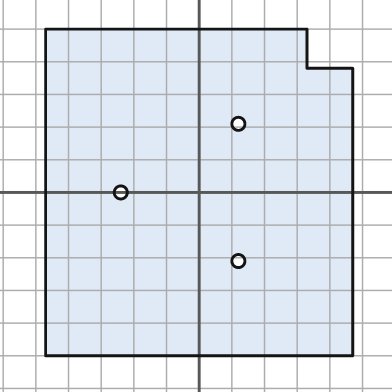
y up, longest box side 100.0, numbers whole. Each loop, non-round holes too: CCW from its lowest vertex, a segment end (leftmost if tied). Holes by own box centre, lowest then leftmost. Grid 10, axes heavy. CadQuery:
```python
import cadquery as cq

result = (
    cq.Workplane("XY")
    .moveTo(-47.0, -50.0)
    .lineTo(47.0, -50.0)
    .lineTo(47.0, 38.0)
    .lineTo(33.0, 38.0)
    .lineTo(33.0, 50.0)
    .lineTo(-47.0, 50.0)
    .close()
    .moveTo(12.0, -21.0)
    .circle(2.0)
    .moveTo(-24.0, 0.0)
    .circle(2.0)
    .moveTo(12.0, 21.0)
    .circle(2.0)
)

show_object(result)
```